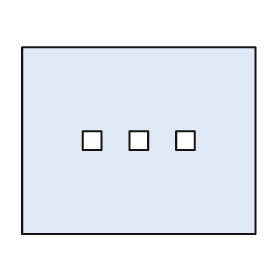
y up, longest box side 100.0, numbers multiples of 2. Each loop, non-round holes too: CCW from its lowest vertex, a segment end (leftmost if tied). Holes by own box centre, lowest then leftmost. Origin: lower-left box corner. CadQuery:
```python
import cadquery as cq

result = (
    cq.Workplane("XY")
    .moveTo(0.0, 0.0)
    .lineTo(100.0, 0.0)
    .lineTo(100.0, 80.0)
    .lineTo(0.0, 80.0)
    .close()
    .moveTo(26.0, 36.0)
    .lineTo(34.0, 36.0)
    .lineTo(34.0, 44.0)
    .lineTo(26.0, 44.0)
    .close()
    .moveTo(46.0, 36.0)
    .lineTo(54.0, 36.0)
    .lineTo(54.0, 44.0)
    .lineTo(46.0, 44.0)
    .close()
    .moveTo(66.0, 36.0)
    .lineTo(74.0, 36.0)
    .lineTo(74.0, 44.0)
    .lineTo(66.0, 44.0)
    .close()
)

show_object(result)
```